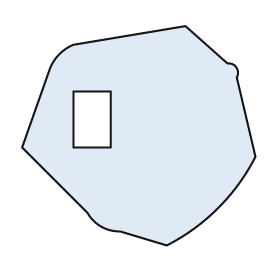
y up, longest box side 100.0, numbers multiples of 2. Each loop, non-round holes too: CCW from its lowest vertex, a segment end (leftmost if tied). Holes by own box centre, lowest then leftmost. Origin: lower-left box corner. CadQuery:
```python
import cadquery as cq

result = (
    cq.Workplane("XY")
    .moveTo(62.0, 0.0)
    .threePointArc((84.0, 16.0), (100.0, 38.0))
    .lineTo(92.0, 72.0)
    .threePointArc((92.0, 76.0), (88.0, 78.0))
    .lineTo(70.0, 94.0)
    .lineTo(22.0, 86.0)
    .threePointArc((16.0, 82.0), (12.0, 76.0))
    .lineTo(0.0, 42.0)
    .lineTo(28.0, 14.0)
    .threePointArc((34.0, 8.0), (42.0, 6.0))
    .close()
    .moveTo(22.0, 42.0)
    .lineTo(38.0, 42.0)
    .lineTo(38.0, 66.0)
    .lineTo(22.0, 66.0)
    .close()
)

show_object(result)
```